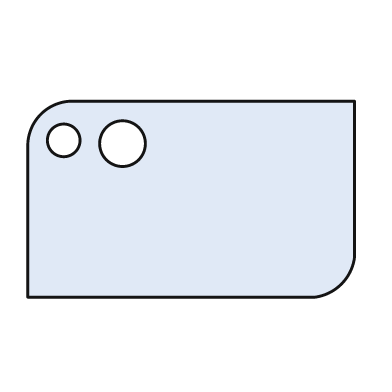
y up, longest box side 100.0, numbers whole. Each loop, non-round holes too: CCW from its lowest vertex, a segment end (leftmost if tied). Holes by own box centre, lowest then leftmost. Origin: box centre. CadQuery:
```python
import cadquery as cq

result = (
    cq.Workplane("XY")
    .moveTo(-50.0, -30.0)
    .lineTo(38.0, -30.0)
    .threePointArc((46.0, -26.0), (50.0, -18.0))
    .lineTo(50.0, 30.0)
    .lineTo(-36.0, 30.0)
    .threePointArc((-46.0, 26.0), (-50.0, 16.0))
    .close()
    .moveTo(-21.0, 17.0)
    .circle(7.0)
    .moveTo(-39.0, 18.0)
    .circle(5.0)
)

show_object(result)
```